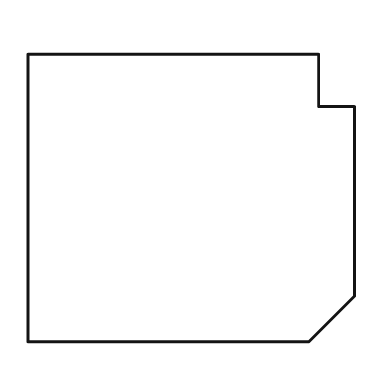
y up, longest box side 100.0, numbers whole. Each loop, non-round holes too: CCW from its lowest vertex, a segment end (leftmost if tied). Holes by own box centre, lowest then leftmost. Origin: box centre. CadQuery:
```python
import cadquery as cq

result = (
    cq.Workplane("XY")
    .moveTo(-50.0, -44.0)
    .lineTo(36.0, -44.0)
    .lineTo(50.0, -30.0)
    .lineTo(50.0, 28.0)
    .lineTo(39.0, 28.0)
    .lineTo(39.0, 44.0)
    .lineTo(-50.0, 44.0)
    .close()
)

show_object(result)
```